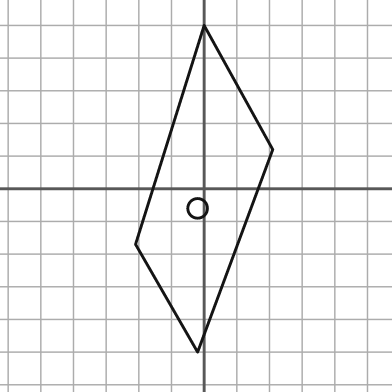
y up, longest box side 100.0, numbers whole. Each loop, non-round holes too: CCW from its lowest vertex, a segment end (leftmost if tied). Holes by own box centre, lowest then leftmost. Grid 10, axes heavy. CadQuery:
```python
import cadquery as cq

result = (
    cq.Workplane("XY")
    .moveTo(-2.0, -50.0)
    .lineTo(21.0, 12.0)
    .lineTo(0.0, 50.0)
    .lineTo(-21.0, -17.0)
    .close()
    .moveTo(-2.0, -6.0)
    .circle(3.0)
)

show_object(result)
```